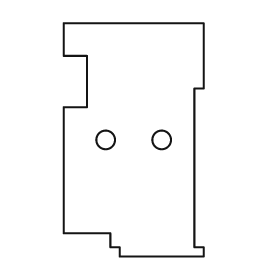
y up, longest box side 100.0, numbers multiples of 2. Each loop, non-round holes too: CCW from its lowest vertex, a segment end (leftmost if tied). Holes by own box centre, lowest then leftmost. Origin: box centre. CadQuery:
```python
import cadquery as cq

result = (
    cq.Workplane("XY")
    .moveTo(-6.0, -50.0)
    .lineTo(30.0, -50.0)
    .lineTo(30.0, -46.0)
    .lineTo(26.0, -46.0)
    .lineTo(26.0, 22.0)
    .lineTo(30.0, 22.0)
    .lineTo(30.0, 50.0)
    .lineTo(-30.0, 50.0)
    .lineTo(-30.0, 36.0)
    .lineTo(-20.0, 36.0)
    .lineTo(-20.0, 14.0)
    .lineTo(-30.0, 14.0)
    .lineTo(-30.0, -40.0)
    .lineTo(-10.0, -40.0)
    .lineTo(-10.0, -46.0)
    .lineTo(-6.0, -46.0)
    .close()
    .moveTo(-12.0, 0.0)
    .circle(4.0)
    .moveTo(12.0, 0.0)
    .circle(4.0)
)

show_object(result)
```